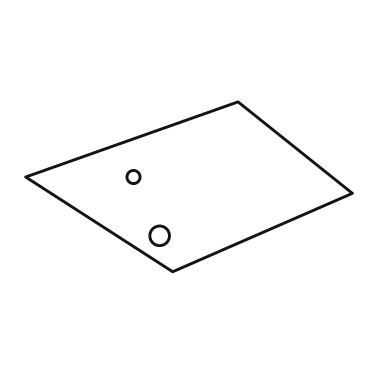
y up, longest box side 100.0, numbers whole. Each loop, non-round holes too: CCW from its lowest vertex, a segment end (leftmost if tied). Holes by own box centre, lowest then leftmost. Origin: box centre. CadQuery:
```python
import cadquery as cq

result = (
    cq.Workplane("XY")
    .moveTo(-5.0, -26.0)
    .lineTo(50.0, -2.0)
    .lineTo(15.0, 26.0)
    .lineTo(-50.0, 3.0)
    .close()
    .moveTo(-9.0, -15.0)
    .circle(3.0)
    .moveTo(-17.0, 3.0)
    .circle(2.0)
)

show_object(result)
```